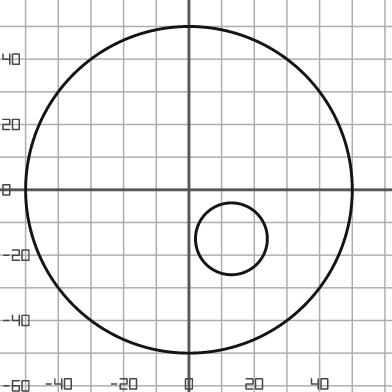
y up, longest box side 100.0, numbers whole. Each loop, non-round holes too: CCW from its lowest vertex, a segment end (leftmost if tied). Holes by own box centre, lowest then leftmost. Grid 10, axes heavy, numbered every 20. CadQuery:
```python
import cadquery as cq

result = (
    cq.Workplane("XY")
    .moveTo(0.0, 0.0)
    .circle(50.0)
    .moveTo(13.0, -15.0)
    .circle(11.0)
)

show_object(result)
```